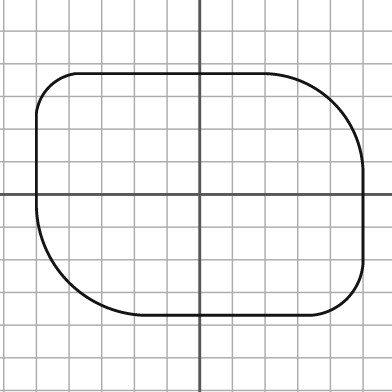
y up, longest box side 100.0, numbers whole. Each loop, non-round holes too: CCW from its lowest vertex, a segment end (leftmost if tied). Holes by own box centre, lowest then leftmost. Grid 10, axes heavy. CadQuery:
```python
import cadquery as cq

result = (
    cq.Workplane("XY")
    .moveTo(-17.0, -37.0)
    .lineTo(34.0, -37.0)
    .threePointArc((45.0, -32.0), (50.0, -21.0))
    .lineTo(50.0, 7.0)
    .threePointArc((41.0, 28.0), (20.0, 37.0))
    .lineTo(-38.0, 37.0)
    .threePointArc((-46.0, 33.0), (-50.0, 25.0))
    .lineTo(-50.0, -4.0)
    .threePointArc((-40.0, -27.0), (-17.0, -37.0))
    .close()
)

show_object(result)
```